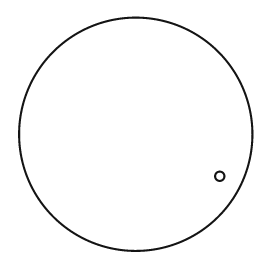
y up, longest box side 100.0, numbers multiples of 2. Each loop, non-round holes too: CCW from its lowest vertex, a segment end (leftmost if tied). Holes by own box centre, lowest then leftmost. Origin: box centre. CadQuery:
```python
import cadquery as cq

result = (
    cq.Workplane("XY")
    .moveTo(0.0, 0.0)
    .circle(50.0)
    .moveTo(36.0, -18.0)
    .circle(2.0)
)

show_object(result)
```